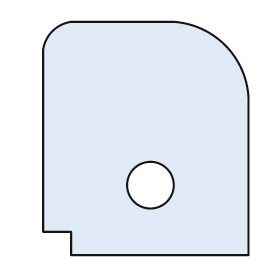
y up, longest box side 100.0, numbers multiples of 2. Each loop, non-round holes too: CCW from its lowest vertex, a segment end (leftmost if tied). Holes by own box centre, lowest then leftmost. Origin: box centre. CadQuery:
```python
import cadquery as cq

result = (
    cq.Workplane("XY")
    .moveTo(-32.0, -50.0)
    .lineTo(44.0, -50.0)
    .lineTo(44.0, 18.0)
    .threePointArc((34.0, 40.0), (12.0, 50.0))
    .lineTo(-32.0, 50.0)
    .threePointArc((-40.0, 46.0), (-44.0, 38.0))
    .lineTo(-44.0, -40.0)
    .lineTo(-32.0, -40.0)
    .close()
    .moveTo(2.0, -20.0)
    .circle(10.0)
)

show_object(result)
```